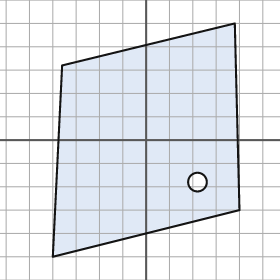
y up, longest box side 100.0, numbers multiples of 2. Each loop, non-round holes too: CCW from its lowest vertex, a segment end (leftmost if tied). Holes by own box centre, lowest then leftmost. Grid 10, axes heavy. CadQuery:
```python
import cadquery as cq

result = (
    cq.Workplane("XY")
    .moveTo(-40.0, -50.0)
    .lineTo(40.0, -30.0)
    .lineTo(38.0, 50.0)
    .lineTo(-36.0, 32.0)
    .close()
    .moveTo(22.0, -18.0)
    .circle(4.0)
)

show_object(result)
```